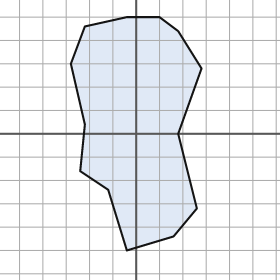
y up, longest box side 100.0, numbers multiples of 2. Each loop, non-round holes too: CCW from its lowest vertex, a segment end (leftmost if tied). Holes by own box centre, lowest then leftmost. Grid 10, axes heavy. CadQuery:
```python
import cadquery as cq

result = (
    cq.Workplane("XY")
    .moveTo(-4.0, -50.0)
    .lineTo(16.0, -44.0)
    .lineTo(26.0, -32.0)
    .lineTo(18.0, 0.0)
    .lineTo(28.0, 28.0)
    .lineTo(18.0, 44.0)
    .lineTo(10.0, 50.0)
    .lineTo(-4.0, 50.0)
    .lineTo(-22.0, 46.0)
    .lineTo(-28.0, 30.0)
    .lineTo(-22.0, 4.0)
    .lineTo(-24.0, -16.0)
    .lineTo(-12.0, -24.0)
    .close()
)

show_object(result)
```